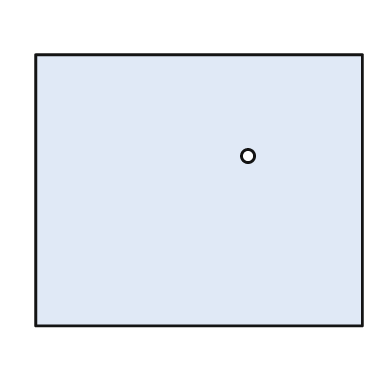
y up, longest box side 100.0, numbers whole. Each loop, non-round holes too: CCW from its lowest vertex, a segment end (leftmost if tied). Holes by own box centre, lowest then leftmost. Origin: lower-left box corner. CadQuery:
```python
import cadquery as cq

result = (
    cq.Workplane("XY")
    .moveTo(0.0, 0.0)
    .lineTo(100.0, 0.0)
    .lineTo(100.0, 83.0)
    .lineTo(0.0, 83.0)
    .close()
    .moveTo(65.0, 52.0)
    .circle(2.0)
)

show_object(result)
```